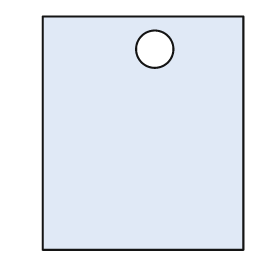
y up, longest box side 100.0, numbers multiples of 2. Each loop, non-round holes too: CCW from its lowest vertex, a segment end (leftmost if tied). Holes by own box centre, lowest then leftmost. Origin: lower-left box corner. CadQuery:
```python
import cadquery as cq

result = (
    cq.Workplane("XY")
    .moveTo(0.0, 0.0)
    .lineTo(86.0, 0.0)
    .lineTo(86.0, 100.0)
    .lineTo(0.0, 100.0)
    .close()
    .moveTo(48.0, 86.0)
    .circle(8.0)
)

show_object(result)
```